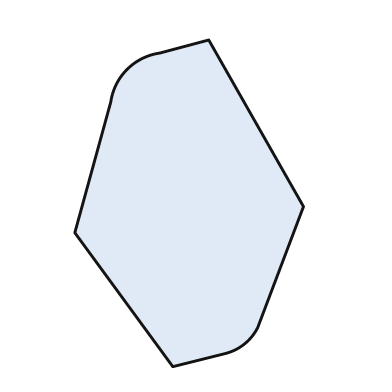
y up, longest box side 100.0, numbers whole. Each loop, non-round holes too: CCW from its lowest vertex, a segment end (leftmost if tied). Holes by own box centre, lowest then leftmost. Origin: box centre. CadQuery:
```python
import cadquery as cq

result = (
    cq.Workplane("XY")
    .moveTo(-5.0, -50.0)
    .lineTo(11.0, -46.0)
    .threePointArc((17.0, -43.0), (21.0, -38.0))
    .lineTo(35.0, -1.0)
    .lineTo(6.0, 50.0)
    .lineTo(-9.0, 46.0)
    .threePointArc((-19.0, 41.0), (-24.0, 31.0))
    .lineTo(-35.0, -9.0)
    .close()
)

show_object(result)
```